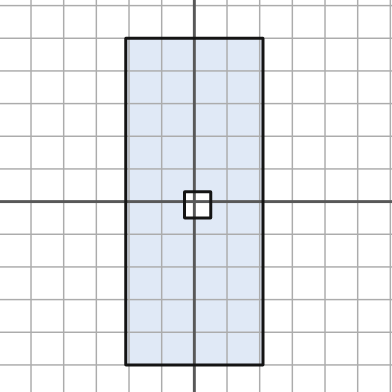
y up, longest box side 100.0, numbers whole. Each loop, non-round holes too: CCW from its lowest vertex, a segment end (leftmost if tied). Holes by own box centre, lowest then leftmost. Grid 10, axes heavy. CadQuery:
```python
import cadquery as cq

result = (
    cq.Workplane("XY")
    .moveTo(-21.0, -50.0)
    .lineTo(21.0, -50.0)
    .lineTo(21.0, 50.0)
    .lineTo(-21.0, 50.0)
    .close()
    .moveTo(-3.0, -5.0)
    .lineTo(5.0, -5.0)
    .lineTo(5.0, 3.0)
    .lineTo(-3.0, 3.0)
    .close()
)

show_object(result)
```